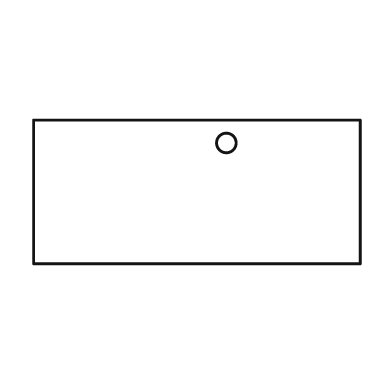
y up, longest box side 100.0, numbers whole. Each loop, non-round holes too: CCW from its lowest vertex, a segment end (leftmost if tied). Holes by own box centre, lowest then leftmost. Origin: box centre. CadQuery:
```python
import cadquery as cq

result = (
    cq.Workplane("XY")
    .moveTo(-50.0, -22.0)
    .lineTo(50.0, -22.0)
    .lineTo(50.0, 22.0)
    .lineTo(-50.0, 22.0)
    .close()
    .moveTo(9.0, 15.0)
    .circle(3.0)
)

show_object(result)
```